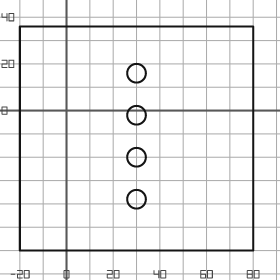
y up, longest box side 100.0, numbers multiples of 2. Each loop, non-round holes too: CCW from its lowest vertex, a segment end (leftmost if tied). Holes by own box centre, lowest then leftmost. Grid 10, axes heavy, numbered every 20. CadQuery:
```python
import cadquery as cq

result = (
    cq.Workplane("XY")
    .moveTo(-20.0, -60.0)
    .lineTo(80.0, -60.0)
    .lineTo(80.0, 36.0)
    .lineTo(-20.0, 36.0)
    .close()
    .moveTo(30.0, -38.0)
    .circle(4.0)
    .moveTo(30.0, -20.0)
    .circle(4.0)
    .moveTo(30.0, -2.0)
    .circle(4.0)
    .moveTo(30.0, 16.0)
    .circle(4.0)
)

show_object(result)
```